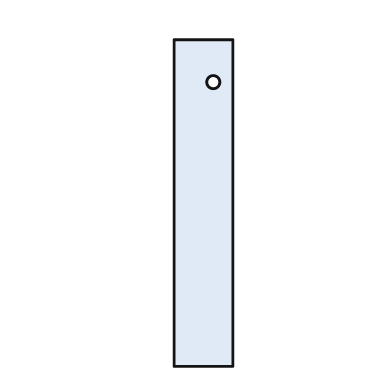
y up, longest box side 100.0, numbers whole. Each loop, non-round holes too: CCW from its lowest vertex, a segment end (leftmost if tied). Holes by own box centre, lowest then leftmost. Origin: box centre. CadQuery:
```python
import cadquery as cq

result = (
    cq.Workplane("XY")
    .moveTo(-9.0, -50.0)
    .lineTo(9.0, -50.0)
    .lineTo(9.0, 50.0)
    .lineTo(-9.0, 50.0)
    .close()
    .moveTo(3.0, 37.0)
    .circle(2.0)
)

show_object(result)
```